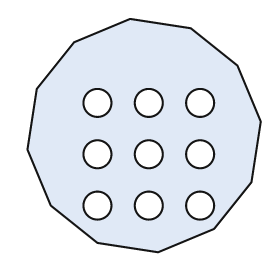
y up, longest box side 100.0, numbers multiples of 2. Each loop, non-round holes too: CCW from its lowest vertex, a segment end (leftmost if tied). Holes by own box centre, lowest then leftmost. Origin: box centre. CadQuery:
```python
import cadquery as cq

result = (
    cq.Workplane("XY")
    .moveTo(6.0, -50.0)
    .lineTo(30.0, -40.0)
    .lineTo(46.0, -20.0)
    .lineTo(50.0, 6.0)
    .lineTo(40.0, 30.0)
    .lineTo(20.0, 46.0)
    .lineTo(-6.0, 50.0)
    .lineTo(-30.0, 40.0)
    .lineTo(-46.0, 20.0)
    .lineTo(-50.0, -6.0)
    .lineTo(-40.0, -30.0)
    .lineTo(-20.0, -46.0)
    .close()
    .moveTo(-20.0, -30.0)
    .circle(6.0)
    .moveTo(2.0, -30.0)
    .circle(6.0)
    .moveTo(24.0, -30.0)
    .circle(6.0)
    .moveTo(-20.0, -8.0)
    .circle(6.0)
    .moveTo(2.0, -8.0)
    .circle(6.0)
    .moveTo(24.0, -8.0)
    .circle(6.0)
    .moveTo(-20.0, 14.0)
    .circle(6.0)
    .moveTo(2.0, 14.0)
    .circle(6.0)
    .moveTo(24.0, 14.0)
    .circle(6.0)
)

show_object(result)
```